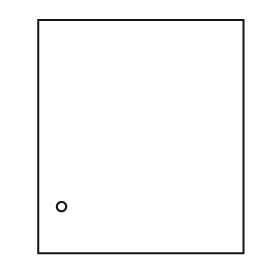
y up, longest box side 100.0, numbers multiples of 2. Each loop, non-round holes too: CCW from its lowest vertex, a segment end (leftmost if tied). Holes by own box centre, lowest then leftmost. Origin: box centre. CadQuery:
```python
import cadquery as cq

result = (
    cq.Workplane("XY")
    .moveTo(-44.0, -50.0)
    .lineTo(44.0, -50.0)
    .lineTo(44.0, 50.0)
    .lineTo(-44.0, 50.0)
    .close()
    .moveTo(-34.0, -30.0)
    .circle(2.0)
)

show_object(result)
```